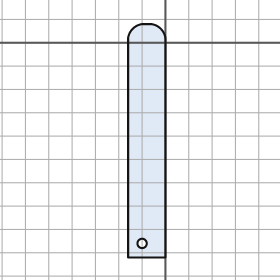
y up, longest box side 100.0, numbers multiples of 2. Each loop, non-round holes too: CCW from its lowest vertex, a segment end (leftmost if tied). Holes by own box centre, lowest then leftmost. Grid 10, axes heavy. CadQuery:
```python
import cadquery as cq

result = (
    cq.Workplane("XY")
    .moveTo(-16.0, -92.0)
    .lineTo(0.0, -92.0)
    .lineTo(0.0, 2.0)
    .threePointArc((-2.0, 6.0), (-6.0, 8.0))
    .lineTo(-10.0, 8.0)
    .threePointArc((-14.0, 6.0), (-16.0, 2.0))
    .close()
    .moveTo(-10.0, -86.0)
    .circle(2.0)
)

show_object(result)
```